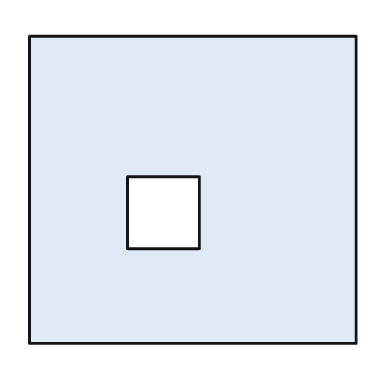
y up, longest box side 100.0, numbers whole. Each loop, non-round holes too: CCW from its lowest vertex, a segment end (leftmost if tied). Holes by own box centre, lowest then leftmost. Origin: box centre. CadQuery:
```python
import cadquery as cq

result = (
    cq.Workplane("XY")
    .moveTo(-50.0, -47.0)
    .lineTo(50.0, -47.0)
    .lineTo(50.0, 47.0)
    .lineTo(-50.0, 47.0)
    .close()
    .moveTo(-20.0, -18.0)
    .lineTo(2.0, -18.0)
    .lineTo(2.0, 4.0)
    .lineTo(-20.0, 4.0)
    .close()
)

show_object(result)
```